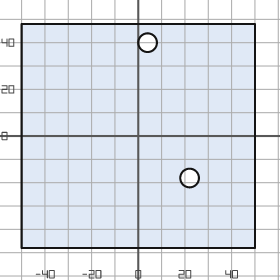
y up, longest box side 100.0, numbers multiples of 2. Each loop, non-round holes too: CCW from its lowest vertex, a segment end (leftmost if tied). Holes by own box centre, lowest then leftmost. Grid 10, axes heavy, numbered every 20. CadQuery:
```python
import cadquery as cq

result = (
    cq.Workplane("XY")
    .moveTo(-50.0, -48.0)
    .lineTo(50.0, -48.0)
    .lineTo(50.0, 48.0)
    .lineTo(-50.0, 48.0)
    .close()
    .moveTo(22.0, -18.0)
    .circle(4.0)
    .moveTo(4.0, 40.0)
    .circle(4.0)
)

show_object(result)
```